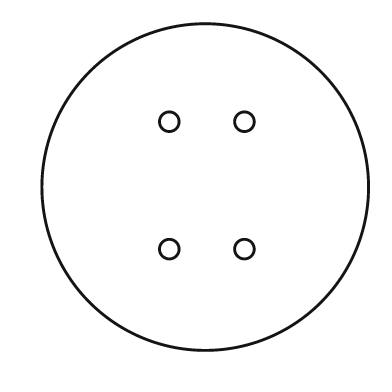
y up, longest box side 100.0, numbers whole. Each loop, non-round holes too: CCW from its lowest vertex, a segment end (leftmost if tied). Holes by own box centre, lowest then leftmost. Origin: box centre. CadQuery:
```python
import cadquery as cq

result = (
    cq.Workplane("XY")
    .moveTo(0.0, 0.0)
    .circle(50.0)
    .moveTo(-11.0, -19.0)
    .circle(3.0)
    .moveTo(12.0, -19.0)
    .circle(3.0)
    .moveTo(-11.0, 20.0)
    .circle(3.0)
    .moveTo(12.0, 20.0)
    .circle(3.0)
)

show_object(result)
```